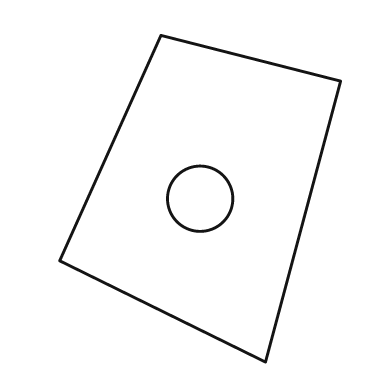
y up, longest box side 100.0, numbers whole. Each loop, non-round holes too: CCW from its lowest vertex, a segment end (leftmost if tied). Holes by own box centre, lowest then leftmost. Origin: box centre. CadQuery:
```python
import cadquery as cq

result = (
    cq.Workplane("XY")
    .moveTo(20.0, -50.0)
    .lineTo(43.0, 36.0)
    .lineTo(-12.0, 50.0)
    .lineTo(-43.0, -19.0)
    .close()
    .moveTo(0.0, 0.0)
    .circle(10.0)
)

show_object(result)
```